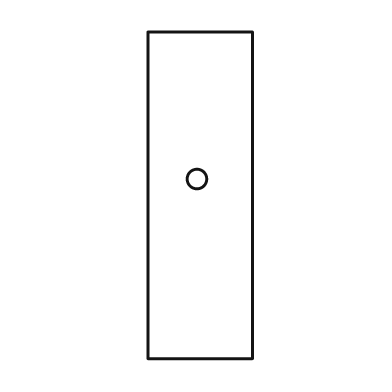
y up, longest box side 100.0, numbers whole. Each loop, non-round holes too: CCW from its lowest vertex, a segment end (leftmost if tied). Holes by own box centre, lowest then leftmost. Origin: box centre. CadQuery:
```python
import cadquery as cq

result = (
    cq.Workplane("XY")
    .moveTo(-16.0, -50.0)
    .lineTo(16.0, -50.0)
    .lineTo(16.0, 50.0)
    .lineTo(-16.0, 50.0)
    .close()
    .moveTo(-1.0, 5.0)
    .circle(3.0)
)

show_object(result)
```